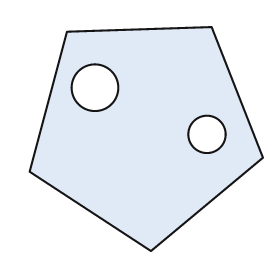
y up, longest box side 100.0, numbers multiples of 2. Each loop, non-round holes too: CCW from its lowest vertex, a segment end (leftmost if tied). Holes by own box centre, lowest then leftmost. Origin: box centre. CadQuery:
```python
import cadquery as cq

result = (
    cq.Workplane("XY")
    .moveTo(2.0, -48.0)
    .lineTo(50.0, -8.0)
    .lineTo(28.0, 48.0)
    .lineTo(-34.0, 46.0)
    .lineTo(-50.0, -14.0)
    .close()
    .moveTo(26.0, 2.0)
    .circle(8.0)
    .moveTo(-22.0, 22.0)
    .circle(10.0)
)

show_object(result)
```